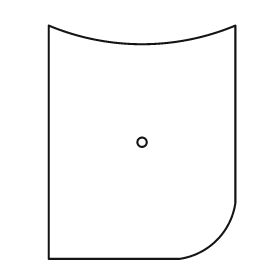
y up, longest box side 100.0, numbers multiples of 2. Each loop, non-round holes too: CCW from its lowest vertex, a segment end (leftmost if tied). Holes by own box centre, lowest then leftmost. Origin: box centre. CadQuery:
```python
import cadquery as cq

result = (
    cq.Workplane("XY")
    .moveTo(-40.0, -50.0)
    .lineTo(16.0, -50.0)
    .threePointArc((32.0, -42.0), (40.0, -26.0))
    .lineTo(40.0, 50.0)
    .threePointArc((0.0, 42.0), (-40.0, 50.0))
    .close()
    .moveTo(0.0, 0.0)
    .circle(2.0)
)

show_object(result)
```